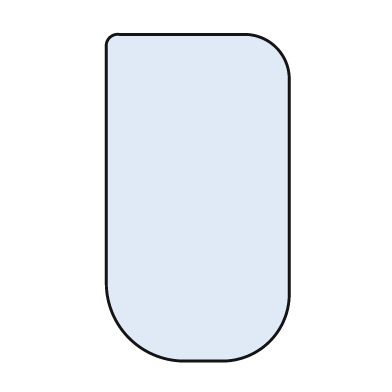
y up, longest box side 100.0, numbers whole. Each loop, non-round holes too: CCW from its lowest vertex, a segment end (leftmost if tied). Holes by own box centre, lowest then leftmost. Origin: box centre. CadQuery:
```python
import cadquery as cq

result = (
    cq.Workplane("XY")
    .moveTo(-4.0, -50.0)
    .lineTo(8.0, -50.0)
    .threePointArc((22.0, -44.0), (28.0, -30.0))
    .lineTo(28.0, 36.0)
    .threePointArc((24.0, 46.0), (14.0, 50.0))
    .lineTo(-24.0, 50.0)
    .threePointArc((-27.0, 49.0), (-28.0, 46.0))
    .lineTo(-28.0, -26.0)
    .threePointArc((-21.0, -43.0), (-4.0, -50.0))
    .close()
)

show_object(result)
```